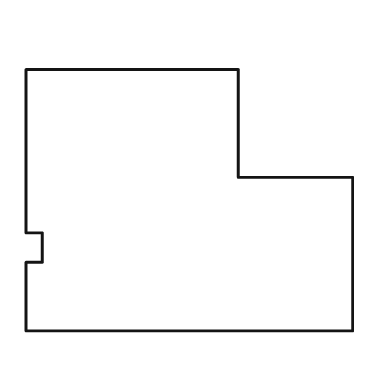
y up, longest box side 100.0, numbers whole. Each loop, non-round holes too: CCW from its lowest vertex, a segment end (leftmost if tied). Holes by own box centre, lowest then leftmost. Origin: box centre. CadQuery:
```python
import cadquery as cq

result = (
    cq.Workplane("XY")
    .moveTo(-50.0, -40.0)
    .lineTo(50.0, -40.0)
    .lineTo(50.0, 7.0)
    .lineTo(15.0, 7.0)
    .lineTo(15.0, 40.0)
    .lineTo(-50.0, 40.0)
    .lineTo(-50.0, -10.0)
    .lineTo(-45.0, -10.0)
    .lineTo(-45.0, -19.0)
    .lineTo(-50.0, -19.0)
    .close()
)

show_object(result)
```